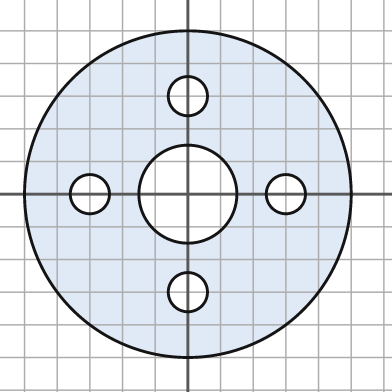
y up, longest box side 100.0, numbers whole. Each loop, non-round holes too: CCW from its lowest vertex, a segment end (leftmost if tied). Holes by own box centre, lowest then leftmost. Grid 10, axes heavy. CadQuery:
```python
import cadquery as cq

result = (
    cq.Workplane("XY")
    .moveTo(0.0, 0.0)
    .circle(50.0)
    .moveTo(0.0, -30.0)
    .circle(6.0)
    .moveTo(-30.0, 0.0)
    .circle(6.0)
    .moveTo(0.0, 0.0)
    .circle(15.0)
    .moveTo(30.0, 0.0)
    .circle(6.0)
    .moveTo(0.0, 30.0)
    .circle(6.0)
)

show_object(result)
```